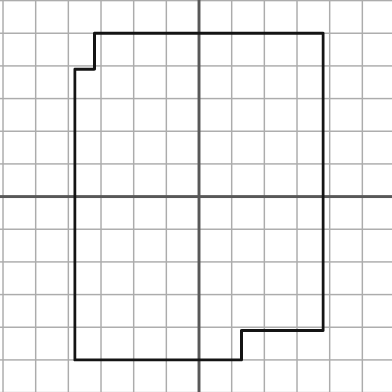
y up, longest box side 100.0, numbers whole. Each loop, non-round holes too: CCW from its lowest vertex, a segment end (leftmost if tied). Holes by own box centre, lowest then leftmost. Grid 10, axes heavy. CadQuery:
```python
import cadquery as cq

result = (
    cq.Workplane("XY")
    .moveTo(-38.0, -50.0)
    .lineTo(13.0, -50.0)
    .lineTo(13.0, -41.0)
    .lineTo(38.0, -41.0)
    .lineTo(38.0, 50.0)
    .lineTo(-32.0, 50.0)
    .lineTo(-32.0, 39.0)
    .lineTo(-38.0, 39.0)
    .close()
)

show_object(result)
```